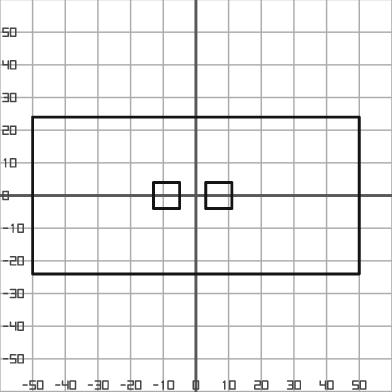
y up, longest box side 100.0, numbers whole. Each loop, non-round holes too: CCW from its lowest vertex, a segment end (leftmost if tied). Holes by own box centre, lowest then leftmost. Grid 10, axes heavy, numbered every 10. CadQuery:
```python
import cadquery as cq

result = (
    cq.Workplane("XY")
    .moveTo(-50.0, -24.0)
    .lineTo(50.0, -24.0)
    .lineTo(50.0, 24.0)
    .lineTo(-50.0, 24.0)
    .close()
    .moveTo(-13.0, -4.0)
    .lineTo(-5.0, -4.0)
    .lineTo(-5.0, 4.0)
    .lineTo(-13.0, 4.0)
    .close()
    .moveTo(3.0, -4.0)
    .lineTo(11.0, -4.0)
    .lineTo(11.0, 4.0)
    .lineTo(3.0, 4.0)
    .close()
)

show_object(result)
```